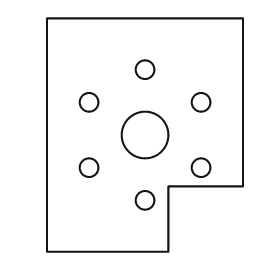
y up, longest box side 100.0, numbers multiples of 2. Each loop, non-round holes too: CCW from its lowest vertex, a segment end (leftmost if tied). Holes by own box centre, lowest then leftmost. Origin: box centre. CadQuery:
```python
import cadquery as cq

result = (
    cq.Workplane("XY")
    .moveTo(-42.0, -50.0)
    .lineTo(10.0, -50.0)
    .lineTo(10.0, -22.0)
    .lineTo(42.0, -22.0)
    .lineTo(42.0, 50.0)
    .lineTo(-42.0, 50.0)
    .close()
    .moveTo(0.0, -28.0)
    .circle(4.0)
    .moveTo(-24.0, -14.0)
    .circle(4.0)
    .moveTo(24.0, -14.0)
    .circle(4.0)
    .moveTo(0.0, 0.0)
    .circle(10.0)
    .moveTo(-24.0, 14.0)
    .circle(4.0)
    .moveTo(24.0, 14.0)
    .circle(4.0)
    .moveTo(0.0, 28.0)
    .circle(4.0)
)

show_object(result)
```